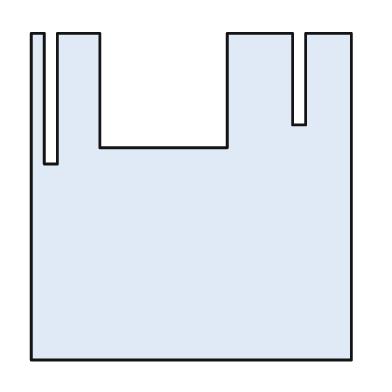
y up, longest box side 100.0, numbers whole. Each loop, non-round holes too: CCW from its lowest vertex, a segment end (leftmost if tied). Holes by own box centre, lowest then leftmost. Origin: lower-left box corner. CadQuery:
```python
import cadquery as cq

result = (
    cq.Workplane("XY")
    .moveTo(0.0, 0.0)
    .lineTo(98.0, 0.0)
    .lineTo(98.0, 100.0)
    .lineTo(84.0, 100.0)
    .lineTo(84.0, 72.0)
    .lineTo(80.0, 72.0)
    .lineTo(80.0, 100.0)
    .lineTo(60.0, 100.0)
    .lineTo(60.0, 65.0)
    .lineTo(21.0, 65.0)
    .lineTo(21.0, 100.0)
    .lineTo(8.0, 100.0)
    .lineTo(8.0, 60.0)
    .lineTo(4.0, 60.0)
    .lineTo(4.0, 100.0)
    .lineTo(0.0, 100.0)
    .close()
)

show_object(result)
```